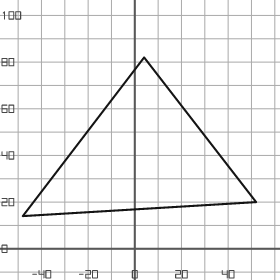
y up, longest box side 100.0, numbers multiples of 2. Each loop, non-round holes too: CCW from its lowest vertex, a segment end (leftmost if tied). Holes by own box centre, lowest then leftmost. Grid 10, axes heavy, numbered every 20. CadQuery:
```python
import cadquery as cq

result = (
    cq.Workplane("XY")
    .moveTo(-48.0, 14.0)
    .lineTo(52.0, 20.0)
    .lineTo(4.0, 82.0)
    .close()
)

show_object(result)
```